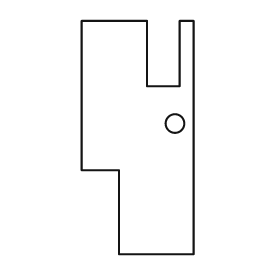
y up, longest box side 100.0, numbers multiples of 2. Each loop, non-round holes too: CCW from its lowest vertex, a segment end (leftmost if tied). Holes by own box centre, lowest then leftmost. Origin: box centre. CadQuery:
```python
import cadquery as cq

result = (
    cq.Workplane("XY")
    .moveTo(-8.0, -50.0)
    .lineTo(24.0, -50.0)
    .lineTo(24.0, 50.0)
    .lineTo(18.0, 50.0)
    .lineTo(18.0, 22.0)
    .lineTo(4.0, 22.0)
    .lineTo(4.0, 50.0)
    .lineTo(-24.0, 50.0)
    .lineTo(-24.0, -14.0)
    .lineTo(-8.0, -14.0)
    .close()
    .moveTo(16.0, 6.0)
    .circle(4.0)
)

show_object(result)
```